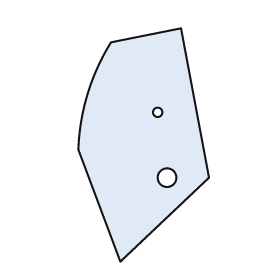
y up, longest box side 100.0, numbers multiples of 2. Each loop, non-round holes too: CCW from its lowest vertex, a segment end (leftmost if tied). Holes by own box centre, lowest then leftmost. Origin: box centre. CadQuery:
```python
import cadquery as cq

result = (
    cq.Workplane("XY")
    .moveTo(-10.0, -50.0)
    .lineTo(28.0, -14.0)
    .lineTo(16.0, 50.0)
    .lineTo(-14.0, 44.0)
    .threePointArc((-24.0, 22.0), (-28.0, -2.0))
    .close()
    .moveTo(10.0, -14.0)
    .circle(4.0)
    .moveTo(6.0, 14.0)
    .circle(2.0)
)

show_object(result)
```